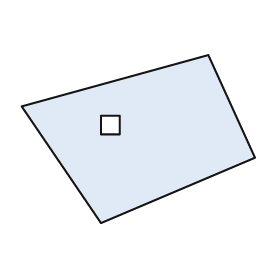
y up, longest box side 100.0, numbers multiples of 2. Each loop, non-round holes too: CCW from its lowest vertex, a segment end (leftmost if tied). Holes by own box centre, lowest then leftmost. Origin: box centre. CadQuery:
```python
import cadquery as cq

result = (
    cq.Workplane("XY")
    .moveTo(-16.0, -36.0)
    .lineTo(50.0, -8.0)
    .lineTo(30.0, 36.0)
    .lineTo(-50.0, 14.0)
    .close()
    .moveTo(-16.0, 2.0)
    .lineTo(-8.0, 2.0)
    .lineTo(-8.0, 10.0)
    .lineTo(-16.0, 10.0)
    .close()
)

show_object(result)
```